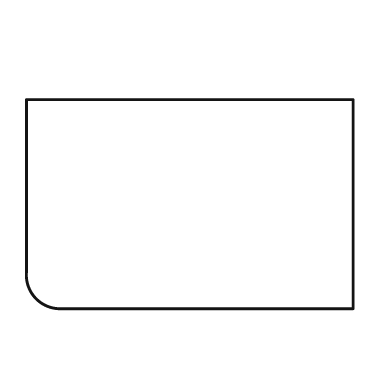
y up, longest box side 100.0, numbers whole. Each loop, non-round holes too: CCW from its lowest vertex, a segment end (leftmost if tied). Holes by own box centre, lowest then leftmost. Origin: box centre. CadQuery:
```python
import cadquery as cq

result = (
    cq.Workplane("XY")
    .moveTo(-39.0, -32.0)
    .lineTo(50.0, -32.0)
    .lineTo(50.0, 32.0)
    .lineTo(-50.0, 32.0)
    .lineTo(-50.0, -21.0)
    .threePointArc((-47.0, -29.0), (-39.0, -32.0))
    .close()
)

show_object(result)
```